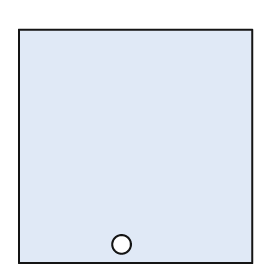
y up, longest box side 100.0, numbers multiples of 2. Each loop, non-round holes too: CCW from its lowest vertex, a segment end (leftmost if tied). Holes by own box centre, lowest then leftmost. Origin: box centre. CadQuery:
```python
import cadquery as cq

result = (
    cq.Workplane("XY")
    .moveTo(-50.0, -50.0)
    .lineTo(50.0, -50.0)
    .lineTo(50.0, 50.0)
    .lineTo(-50.0, 50.0)
    .close()
    .moveTo(-6.0, -42.0)
    .circle(4.0)
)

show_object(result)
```